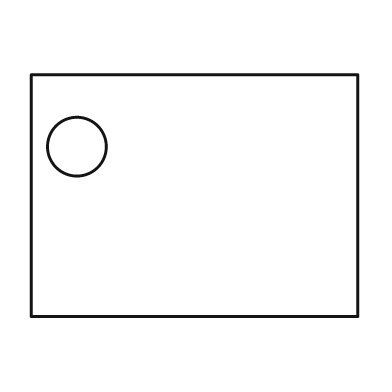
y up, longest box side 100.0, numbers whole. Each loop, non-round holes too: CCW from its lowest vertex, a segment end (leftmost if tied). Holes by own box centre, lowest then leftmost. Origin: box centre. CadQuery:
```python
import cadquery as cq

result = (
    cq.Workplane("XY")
    .moveTo(-50.0, -37.0)
    .lineTo(50.0, -37.0)
    .lineTo(50.0, 37.0)
    .lineTo(-50.0, 37.0)
    .close()
    .moveTo(-36.0, 15.0)
    .circle(9.0)
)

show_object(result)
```